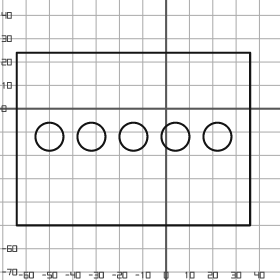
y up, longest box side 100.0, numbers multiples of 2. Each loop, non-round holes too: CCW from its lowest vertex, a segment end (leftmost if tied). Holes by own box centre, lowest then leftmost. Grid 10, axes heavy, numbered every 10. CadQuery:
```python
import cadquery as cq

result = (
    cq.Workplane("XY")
    .moveTo(-64.0, -50.0)
    .lineTo(36.0, -50.0)
    .lineTo(36.0, 24.0)
    .lineTo(-64.0, 24.0)
    .close()
    .moveTo(-50.0, -12.0)
    .circle(6.0)
    .moveTo(-32.0, -12.0)
    .circle(6.0)
    .moveTo(-14.0, -12.0)
    .circle(6.0)
    .moveTo(4.0, -12.0)
    .circle(6.0)
    .moveTo(22.0, -12.0)
    .circle(6.0)
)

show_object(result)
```